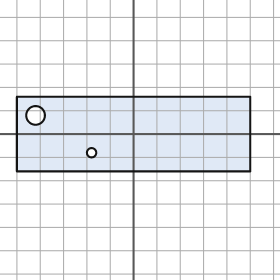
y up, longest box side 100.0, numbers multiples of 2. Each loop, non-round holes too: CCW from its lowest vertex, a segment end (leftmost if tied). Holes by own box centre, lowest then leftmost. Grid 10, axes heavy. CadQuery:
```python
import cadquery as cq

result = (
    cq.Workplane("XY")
    .moveTo(-50.0, -16.0)
    .lineTo(50.0, -16.0)
    .lineTo(50.0, 16.0)
    .lineTo(-50.0, 16.0)
    .close()
    .moveTo(-18.0, -8.0)
    .circle(2.0)
    .moveTo(-42.0, 8.0)
    .circle(4.0)
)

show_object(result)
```